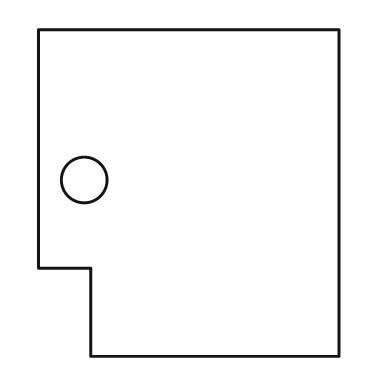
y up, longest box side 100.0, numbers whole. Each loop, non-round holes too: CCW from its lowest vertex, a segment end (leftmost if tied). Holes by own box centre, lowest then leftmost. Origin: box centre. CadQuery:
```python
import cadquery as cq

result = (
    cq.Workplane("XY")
    .moveTo(-30.0, -50.0)
    .lineTo(46.0, -50.0)
    .lineTo(46.0, 50.0)
    .lineTo(-46.0, 50.0)
    .lineTo(-46.0, -23.0)
    .lineTo(-30.0, -23.0)
    .close()
    .moveTo(-32.0, 4.0)
    .circle(7.0)
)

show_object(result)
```